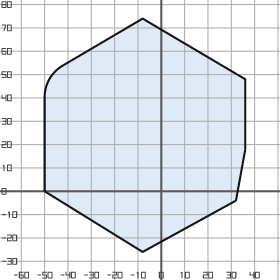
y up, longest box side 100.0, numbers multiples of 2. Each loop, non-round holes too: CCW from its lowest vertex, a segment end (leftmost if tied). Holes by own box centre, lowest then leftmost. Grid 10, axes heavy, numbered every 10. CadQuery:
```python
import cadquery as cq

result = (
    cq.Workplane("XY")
    .moveTo(-8.0, -26.0)
    .lineTo(32.0, -4.0)
    .lineTo(36.0, 18.0)
    .lineTo(36.0, 48.0)
    .lineTo(-8.0, 74.0)
    .lineTo(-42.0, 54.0)
    .threePointArc((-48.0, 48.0), (-50.0, 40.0))
    .lineTo(-50.0, 0.0)
    .close()
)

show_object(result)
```